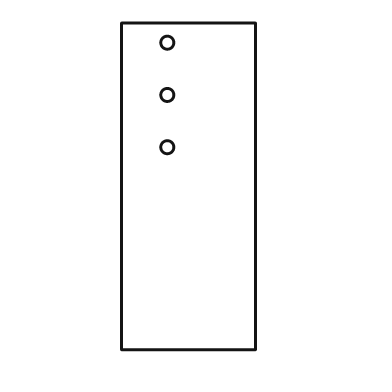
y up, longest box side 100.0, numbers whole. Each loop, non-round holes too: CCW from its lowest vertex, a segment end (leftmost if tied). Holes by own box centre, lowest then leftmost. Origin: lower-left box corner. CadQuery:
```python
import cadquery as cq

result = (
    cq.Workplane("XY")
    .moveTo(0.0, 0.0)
    .lineTo(41.0, 0.0)
    .lineTo(41.0, 100.0)
    .lineTo(0.0, 100.0)
    .close()
    .moveTo(14.0, 62.0)
    .circle(2.0)
    .moveTo(14.0, 78.0)
    .circle(2.0)
    .moveTo(14.0, 94.0)
    .circle(2.0)
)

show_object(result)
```